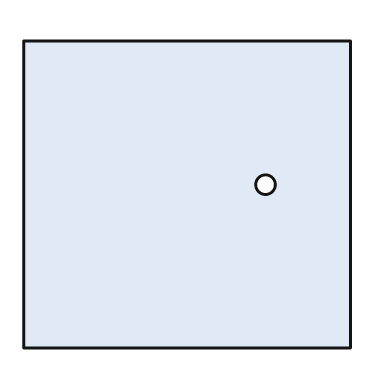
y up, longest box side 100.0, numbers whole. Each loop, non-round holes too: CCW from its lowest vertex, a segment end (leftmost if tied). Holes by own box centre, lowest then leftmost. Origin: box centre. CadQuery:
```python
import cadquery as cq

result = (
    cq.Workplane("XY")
    .moveTo(-50.0, -47.0)
    .lineTo(50.0, -47.0)
    .lineTo(50.0, 47.0)
    .lineTo(-50.0, 47.0)
    .close()
    .moveTo(24.0, 3.0)
    .circle(3.0)
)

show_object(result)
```